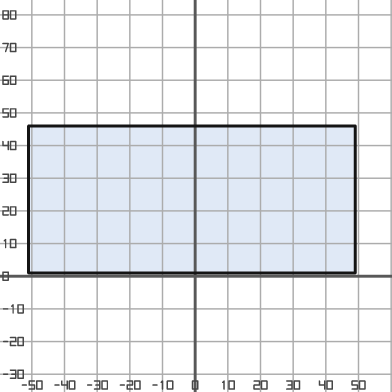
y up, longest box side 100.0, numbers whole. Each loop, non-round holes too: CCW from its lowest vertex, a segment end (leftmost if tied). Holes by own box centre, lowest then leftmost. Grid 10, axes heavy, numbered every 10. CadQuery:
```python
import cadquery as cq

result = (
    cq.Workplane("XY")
    .moveTo(-51.0, 1.0)
    .lineTo(49.0, 1.0)
    .lineTo(49.0, 46.0)
    .lineTo(-51.0, 46.0)
    .close()
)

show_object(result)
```